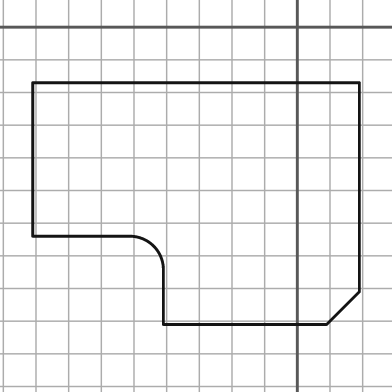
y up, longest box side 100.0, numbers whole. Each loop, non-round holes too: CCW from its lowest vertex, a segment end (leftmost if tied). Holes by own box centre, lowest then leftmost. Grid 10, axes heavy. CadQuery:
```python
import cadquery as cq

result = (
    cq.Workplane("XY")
    .moveTo(-41.0, -91.0)
    .lineTo(9.0, -91.0)
    .lineTo(19.0, -81.0)
    .lineTo(19.0, -17.0)
    .lineTo(-81.0, -17.0)
    .lineTo(-81.0, -64.0)
    .lineTo(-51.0, -64.0)
    .threePointArc((-44.0, -67.0), (-41.0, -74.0))
    .close()
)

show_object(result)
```